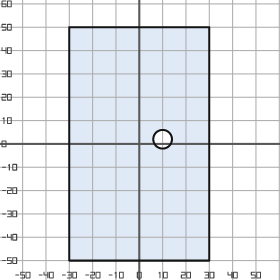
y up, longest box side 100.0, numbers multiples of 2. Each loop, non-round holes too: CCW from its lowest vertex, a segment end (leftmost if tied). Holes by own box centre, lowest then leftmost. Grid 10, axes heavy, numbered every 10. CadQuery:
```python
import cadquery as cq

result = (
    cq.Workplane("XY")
    .moveTo(-30.0, -50.0)
    .lineTo(30.0, -50.0)
    .lineTo(30.0, 50.0)
    .lineTo(-30.0, 50.0)
    .close()
    .moveTo(10.0, 2.0)
    .circle(4.0)
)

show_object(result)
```